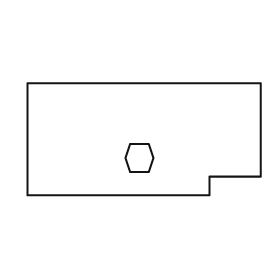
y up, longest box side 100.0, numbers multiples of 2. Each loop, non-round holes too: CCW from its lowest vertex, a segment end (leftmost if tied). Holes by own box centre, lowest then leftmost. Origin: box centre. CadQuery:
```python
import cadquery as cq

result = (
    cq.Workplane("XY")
    .moveTo(-50.0, -24.0)
    .lineTo(28.0, -24.0)
    .lineTo(28.0, -16.0)
    .lineTo(50.0, -16.0)
    .lineTo(50.0, 24.0)
    .lineTo(-50.0, 24.0)
    .close()
    .moveTo(-6.0, -14.0)
    .lineTo(2.0, -14.0)
    .lineTo(4.0, -8.0)
    .lineTo(2.0, -2.0)
    .lineTo(-6.0, -2.0)
    .lineTo(-8.0, -8.0)
    .close()
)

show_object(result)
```